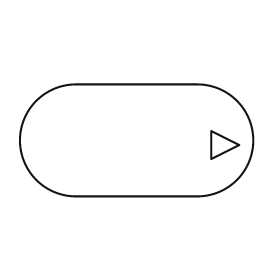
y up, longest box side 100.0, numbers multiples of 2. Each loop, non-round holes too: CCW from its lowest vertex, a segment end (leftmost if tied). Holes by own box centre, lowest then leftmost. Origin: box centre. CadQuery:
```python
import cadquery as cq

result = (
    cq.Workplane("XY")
    .moveTo(-26.0, -24.0)
    .lineTo(26.0, -24.0)
    .threePointArc((50.0, 0.0), (26.0, 24.0))
    .lineTo(-26.0, 24.0)
    .threePointArc((-50.0, 0.0), (-26.0, -24.0))
    .close()
    .moveTo(32.0, -8.0)
    .lineTo(44.0, -2.0)
    .lineTo(32.0, 4.0)
    .close()
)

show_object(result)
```